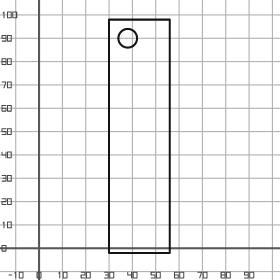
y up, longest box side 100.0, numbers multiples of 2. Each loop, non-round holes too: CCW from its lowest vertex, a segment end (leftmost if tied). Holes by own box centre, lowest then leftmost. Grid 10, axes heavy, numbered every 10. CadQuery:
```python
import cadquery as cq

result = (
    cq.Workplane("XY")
    .moveTo(30.0, -2.0)
    .lineTo(56.0, -2.0)
    .lineTo(56.0, 98.0)
    .lineTo(30.0, 98.0)
    .close()
    .moveTo(38.0, 90.0)
    .circle(4.0)
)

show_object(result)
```